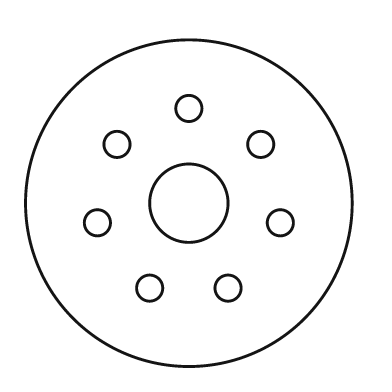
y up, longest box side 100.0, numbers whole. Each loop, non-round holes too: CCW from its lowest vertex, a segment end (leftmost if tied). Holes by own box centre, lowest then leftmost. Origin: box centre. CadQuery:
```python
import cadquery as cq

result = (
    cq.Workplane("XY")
    .moveTo(0.0, 0.0)
    .circle(50.0)
    .moveTo(-12.0, -26.0)
    .circle(4.0)
    .moveTo(12.0, -26.0)
    .circle(4.0)
    .moveTo(-28.0, -6.0)
    .circle(4.0)
    .moveTo(28.0, -6.0)
    .circle(4.0)
    .moveTo(0.0, 0.0)
    .circle(12.0)
    .moveTo(-22.0, 18.0)
    .circle(4.0)
    .moveTo(22.0, 18.0)
    .circle(4.0)
    .moveTo(0.0, 29.0)
    .circle(4.0)
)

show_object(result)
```